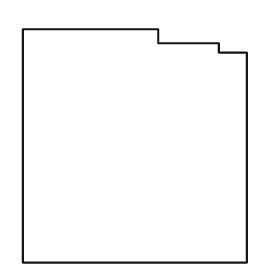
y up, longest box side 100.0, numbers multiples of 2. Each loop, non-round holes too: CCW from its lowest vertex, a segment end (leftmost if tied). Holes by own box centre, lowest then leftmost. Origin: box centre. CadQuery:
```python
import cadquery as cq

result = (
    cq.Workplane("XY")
    .moveTo(-48.0, -50.0)
    .lineTo(48.0, -50.0)
    .lineTo(48.0, 40.0)
    .lineTo(36.0, 40.0)
    .lineTo(36.0, 44.0)
    .lineTo(10.0, 44.0)
    .lineTo(10.0, 50.0)
    .lineTo(-48.0, 50.0)
    .close()
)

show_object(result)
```